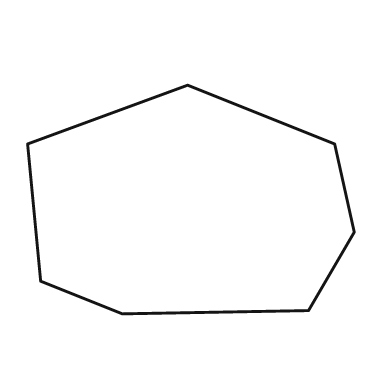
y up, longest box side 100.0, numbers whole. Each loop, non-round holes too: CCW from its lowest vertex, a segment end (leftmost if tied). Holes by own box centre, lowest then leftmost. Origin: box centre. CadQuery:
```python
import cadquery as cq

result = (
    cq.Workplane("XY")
    .moveTo(-21.0, -35.0)
    .lineTo(36.0, -34.0)
    .lineTo(50.0, -10.0)
    .lineTo(44.0, 17.0)
    .lineTo(-1.0, 35.0)
    .lineTo(-50.0, 17.0)
    .lineTo(-46.0, -25.0)
    .close()
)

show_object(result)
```